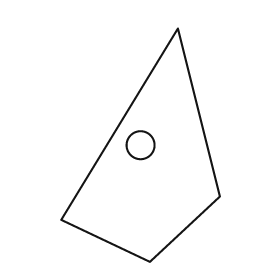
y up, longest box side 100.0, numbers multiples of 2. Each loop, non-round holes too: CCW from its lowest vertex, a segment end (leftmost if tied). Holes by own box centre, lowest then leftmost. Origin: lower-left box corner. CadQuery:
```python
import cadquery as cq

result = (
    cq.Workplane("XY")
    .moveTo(38.0, 0.0)
    .lineTo(68.0, 28.0)
    .lineTo(50.0, 100.0)
    .lineTo(0.0, 18.0)
    .close()
    .moveTo(34.0, 50.0)
    .circle(6.0)
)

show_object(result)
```